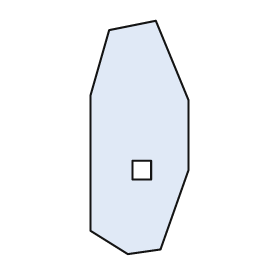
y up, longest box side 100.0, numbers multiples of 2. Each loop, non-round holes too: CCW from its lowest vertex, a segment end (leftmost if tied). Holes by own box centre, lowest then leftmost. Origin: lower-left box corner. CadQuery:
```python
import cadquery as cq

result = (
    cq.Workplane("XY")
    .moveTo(16.0, 0.0)
    .lineTo(30.0, 2.0)
    .lineTo(42.0, 36.0)
    .lineTo(42.0, 66.0)
    .lineTo(28.0, 100.0)
    .lineTo(8.0, 96.0)
    .lineTo(0.0, 68.0)
    .lineTo(0.0, 10.0)
    .close()
    .moveTo(18.0, 32.0)
    .lineTo(26.0, 32.0)
    .lineTo(26.0, 40.0)
    .lineTo(18.0, 40.0)
    .close()
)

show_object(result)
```